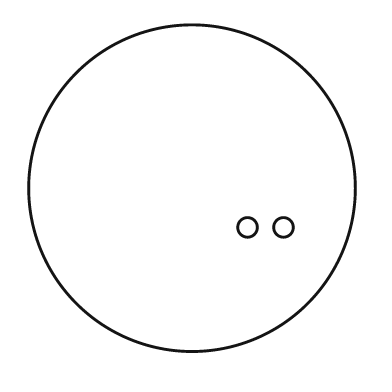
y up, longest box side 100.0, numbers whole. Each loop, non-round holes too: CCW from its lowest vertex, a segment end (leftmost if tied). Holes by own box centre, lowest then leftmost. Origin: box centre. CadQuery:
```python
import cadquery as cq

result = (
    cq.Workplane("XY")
    .moveTo(0.0, 0.0)
    .circle(50.0)
    .moveTo(17.0, -12.0)
    .circle(3.0)
    .moveTo(28.0, -12.0)
    .circle(3.0)
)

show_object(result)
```